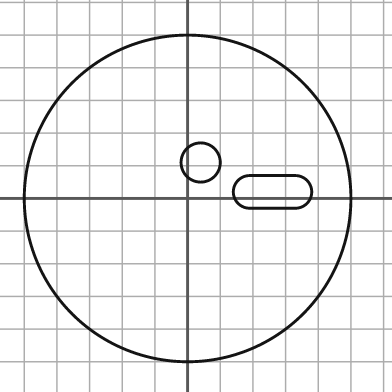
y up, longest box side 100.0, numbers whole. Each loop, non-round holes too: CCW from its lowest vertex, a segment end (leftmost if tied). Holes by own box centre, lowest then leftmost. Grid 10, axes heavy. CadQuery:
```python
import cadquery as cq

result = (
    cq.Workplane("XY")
    .moveTo(0.0, 0.0)
    .circle(50.0)
    .moveTo(19.0, -3.0)
    .lineTo(33.0, -3.0)
    .threePointArc((38.0, 2.0), (33.0, 7.0))
    .lineTo(19.0, 7.0)
    .threePointArc((14.0, 2.0), (19.0, -3.0))
    .close()
    .moveTo(4.0, 11.0)
    .circle(6.0)
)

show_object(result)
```